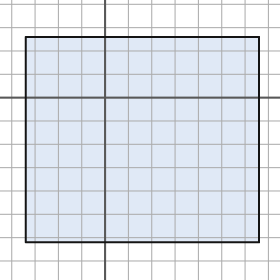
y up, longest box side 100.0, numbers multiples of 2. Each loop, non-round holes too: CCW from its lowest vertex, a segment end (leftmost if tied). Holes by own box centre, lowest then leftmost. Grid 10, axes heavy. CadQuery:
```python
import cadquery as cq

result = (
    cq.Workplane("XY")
    .moveTo(-34.0, -62.0)
    .lineTo(66.0, -62.0)
    .lineTo(66.0, 26.0)
    .lineTo(-34.0, 26.0)
    .close()
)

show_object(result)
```